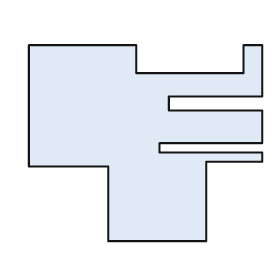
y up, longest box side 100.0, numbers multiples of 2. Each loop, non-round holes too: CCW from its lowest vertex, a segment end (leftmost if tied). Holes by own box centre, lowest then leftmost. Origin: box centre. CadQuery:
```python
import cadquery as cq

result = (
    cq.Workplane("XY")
    .moveTo(-16.0, -42.0)
    .lineTo(26.0, -42.0)
    .lineTo(26.0, -8.0)
    .lineTo(50.0, -8.0)
    .lineTo(50.0, -4.0)
    .lineTo(6.0, -4.0)
    .lineTo(6.0, 0.0)
    .lineTo(50.0, 0.0)
    .lineTo(50.0, 14.0)
    .lineTo(10.0, 14.0)
    .lineTo(10.0, 20.0)
    .lineTo(50.0, 20.0)
    .lineTo(50.0, 42.0)
    .lineTo(42.0, 42.0)
    .lineTo(42.0, 30.0)
    .lineTo(-4.0, 30.0)
    .lineTo(-4.0, 42.0)
    .lineTo(-50.0, 42.0)
    .lineTo(-50.0, -10.0)
    .lineTo(-16.0, -10.0)
    .close()
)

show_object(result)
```